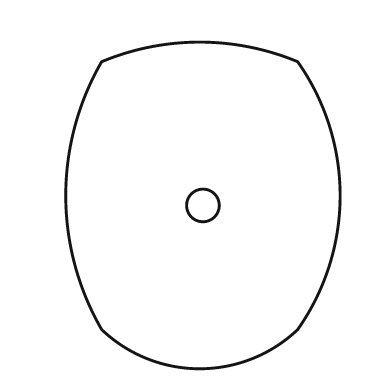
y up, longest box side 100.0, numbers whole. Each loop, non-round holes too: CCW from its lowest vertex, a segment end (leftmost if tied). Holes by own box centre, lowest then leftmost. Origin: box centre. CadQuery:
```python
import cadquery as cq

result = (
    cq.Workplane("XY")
    .moveTo(-31.0, -38.0)
    .threePointArc((-1.0, -50.0), (29.0, -38.0))
    .threePointArc((42.0, 3.0), (29.0, 44.0))
    .threePointArc((-1.0, 50.0), (-31.0, 44.0))
    .threePointArc((-42.0, 3.0), (-31.0, -38.0))
    .close()
    .moveTo(0.0, 0.0)
    .circle(5.0)
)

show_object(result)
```